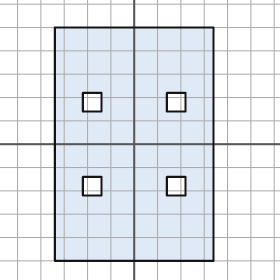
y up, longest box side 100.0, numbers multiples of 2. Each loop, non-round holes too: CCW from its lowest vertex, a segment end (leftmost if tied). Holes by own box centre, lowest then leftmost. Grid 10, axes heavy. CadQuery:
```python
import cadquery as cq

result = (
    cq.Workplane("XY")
    .moveTo(-34.0, -50.0)
    .lineTo(34.0, -50.0)
    .lineTo(34.0, 50.0)
    .lineTo(-34.0, 50.0)
    .close()
    .moveTo(-22.0, -22.0)
    .lineTo(-14.0, -22.0)
    .lineTo(-14.0, -14.0)
    .lineTo(-22.0, -14.0)
    .close()
    .moveTo(14.0, -22.0)
    .lineTo(22.0, -22.0)
    .lineTo(22.0, -14.0)
    .lineTo(14.0, -14.0)
    .close()
    .moveTo(-22.0, 14.0)
    .lineTo(-14.0, 14.0)
    .lineTo(-14.0, 22.0)
    .lineTo(-22.0, 22.0)
    .close()
    .moveTo(14.0, 14.0)
    .lineTo(22.0, 14.0)
    .lineTo(22.0, 22.0)
    .lineTo(14.0, 22.0)
    .close()
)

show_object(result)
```